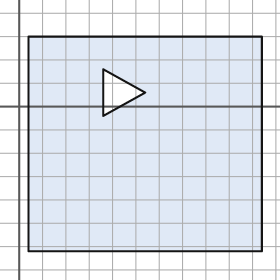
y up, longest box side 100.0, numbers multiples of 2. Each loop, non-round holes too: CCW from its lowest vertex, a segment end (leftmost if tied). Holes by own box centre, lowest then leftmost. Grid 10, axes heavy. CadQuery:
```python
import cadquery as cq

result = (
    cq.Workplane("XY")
    .moveTo(4.0, -62.0)
    .lineTo(104.0, -62.0)
    .lineTo(104.0, 30.0)
    .lineTo(4.0, 30.0)
    .close()
    .moveTo(36.0, -4.0)
    .lineTo(54.0, 6.0)
    .lineTo(36.0, 16.0)
    .close()
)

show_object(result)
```